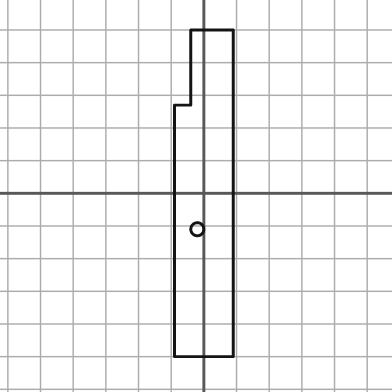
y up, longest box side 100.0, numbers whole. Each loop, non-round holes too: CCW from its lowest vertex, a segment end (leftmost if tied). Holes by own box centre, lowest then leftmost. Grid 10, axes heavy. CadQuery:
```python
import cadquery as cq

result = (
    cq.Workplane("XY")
    .moveTo(-9.0, -50.0)
    .lineTo(9.0, -50.0)
    .lineTo(9.0, 50.0)
    .lineTo(-4.0, 50.0)
    .lineTo(-4.0, 27.0)
    .lineTo(-9.0, 27.0)
    .close()
    .moveTo(-2.0, -11.0)
    .circle(2.0)
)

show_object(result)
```